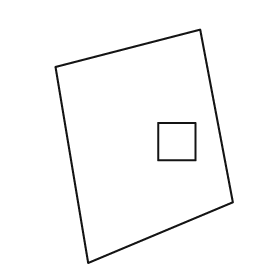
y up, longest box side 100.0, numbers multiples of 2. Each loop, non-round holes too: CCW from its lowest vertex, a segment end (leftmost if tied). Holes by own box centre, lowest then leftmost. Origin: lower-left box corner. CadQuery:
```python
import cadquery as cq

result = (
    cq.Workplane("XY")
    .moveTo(14.0, 0.0)
    .lineTo(76.0, 26.0)
    .lineTo(62.0, 100.0)
    .lineTo(0.0, 84.0)
    .close()
    .moveTo(44.0, 44.0)
    .lineTo(60.0, 44.0)
    .lineTo(60.0, 60.0)
    .lineTo(44.0, 60.0)
    .close()
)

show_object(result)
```